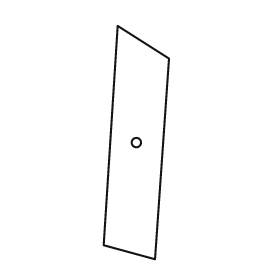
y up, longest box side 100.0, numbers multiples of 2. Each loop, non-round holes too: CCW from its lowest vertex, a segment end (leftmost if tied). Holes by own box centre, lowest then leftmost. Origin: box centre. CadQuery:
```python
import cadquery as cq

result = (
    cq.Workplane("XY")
    .moveTo(8.0, -50.0)
    .lineTo(14.0, 36.0)
    .lineTo(-8.0, 50.0)
    .lineTo(-14.0, -44.0)
    .close()
    .moveTo(0.0, 0.0)
    .circle(2.0)
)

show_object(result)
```